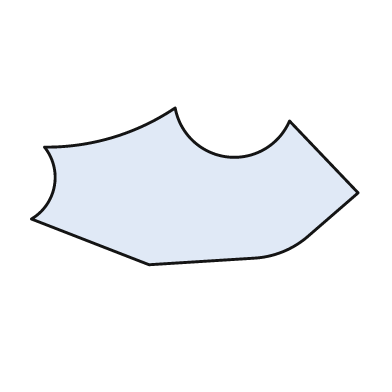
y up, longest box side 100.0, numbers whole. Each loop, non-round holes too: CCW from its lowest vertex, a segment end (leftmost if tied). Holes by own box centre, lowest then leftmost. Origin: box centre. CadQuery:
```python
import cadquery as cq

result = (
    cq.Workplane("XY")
    .moveTo(-14.0, -24.0)
    .lineTo(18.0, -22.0)
    .threePointArc((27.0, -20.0), (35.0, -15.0))
    .lineTo(50.0, -2.0)
    .lineTo(29.0, 20.0)
    .threePointArc((10.0, 9.0), (-6.0, 24.0))
    .threePointArc((-25.0, 15.0), (-46.0, 12.0))
    .threePointArc((-43.0, 0.0), (-50.0, -10.0))
    .close()
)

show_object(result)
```